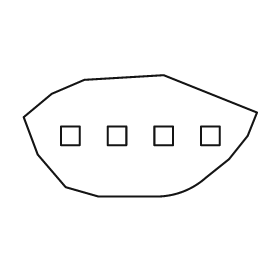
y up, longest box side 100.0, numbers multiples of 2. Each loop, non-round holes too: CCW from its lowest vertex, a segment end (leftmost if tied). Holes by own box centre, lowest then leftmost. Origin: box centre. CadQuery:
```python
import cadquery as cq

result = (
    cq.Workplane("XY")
    .moveTo(-18.0, -26.0)
    .lineTo(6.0, -26.0)
    .threePointArc((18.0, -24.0), (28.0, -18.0))
    .lineTo(38.0, -10.0)
    .lineTo(46.0, 0.0)
    .lineTo(50.0, 10.0)
    .lineTo(10.0, 26.0)
    .lineTo(-24.0, 24.0)
    .lineTo(-38.0, 18.0)
    .lineTo(-50.0, 8.0)
    .lineTo(-44.0, -8.0)
    .lineTo(-32.0, -22.0)
    .close()
    .moveTo(-34.0, -4.0)
    .lineTo(-26.0, -4.0)
    .lineTo(-26.0, 4.0)
    .lineTo(-34.0, 4.0)
    .close()
    .moveTo(-14.0, -4.0)
    .lineTo(-6.0, -4.0)
    .lineTo(-6.0, 4.0)
    .lineTo(-14.0, 4.0)
    .close()
    .moveTo(6.0, -4.0)
    .lineTo(14.0, -4.0)
    .lineTo(14.0, 4.0)
    .lineTo(6.0, 4.0)
    .close()
    .moveTo(26.0, -4.0)
    .lineTo(34.0, -4.0)
    .lineTo(34.0, 4.0)
    .lineTo(26.0, 4.0)
    .close()
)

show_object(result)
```